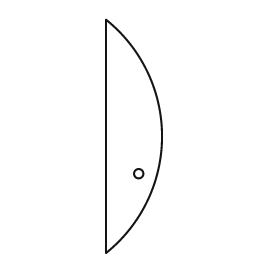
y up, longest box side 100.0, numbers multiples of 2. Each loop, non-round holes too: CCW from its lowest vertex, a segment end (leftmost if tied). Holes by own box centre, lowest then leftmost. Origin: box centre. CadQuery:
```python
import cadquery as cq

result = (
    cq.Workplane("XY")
    .moveTo(-12.0, -50.0)
    .threePointArc((12.0, 0.0), (-12.0, 50.0))
    .close()
    .moveTo(2.0, -16.0)
    .circle(2.0)
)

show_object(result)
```